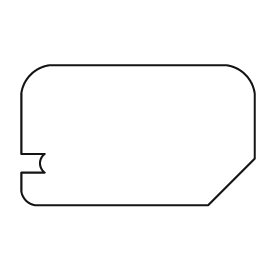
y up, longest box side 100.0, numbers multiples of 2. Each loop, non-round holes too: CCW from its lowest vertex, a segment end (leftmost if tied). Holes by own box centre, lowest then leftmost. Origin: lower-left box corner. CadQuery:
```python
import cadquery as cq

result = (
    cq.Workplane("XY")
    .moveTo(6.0, 0.0)
    .lineTo(80.0, 0.0)
    .lineTo(100.0, 20.0)
    .lineTo(100.0, 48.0)
    .threePointArc((96.0, 56.0), (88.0, 60.0))
    .lineTo(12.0, 60.0)
    .threePointArc((4.0, 56.0), (0.0, 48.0))
    .lineTo(0.0, 22.0)
    .lineTo(10.0, 22.0)
    .threePointArc((8.0, 18.0), (10.0, 14.0))
    .lineTo(0.0, 14.0)
    .lineTo(0.0, 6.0)
    .threePointArc((2.0, 2.0), (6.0, 0.0))
    .close()
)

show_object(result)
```